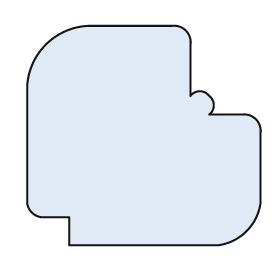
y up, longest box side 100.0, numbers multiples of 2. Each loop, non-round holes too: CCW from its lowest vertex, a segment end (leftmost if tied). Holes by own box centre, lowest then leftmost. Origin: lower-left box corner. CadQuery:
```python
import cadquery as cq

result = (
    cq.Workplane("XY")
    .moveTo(18.0, 0.0)
    .lineTo(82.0, 0.0)
    .threePointArc((94.0, 6.0), (100.0, 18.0))
    .lineTo(100.0, 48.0)
    .threePointArc((98.0, 54.0), (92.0, 56.0))
    .lineTo(78.0, 56.0)
    .threePointArc((80.0, 60.0), (78.0, 64.0))
    .threePointArc((74.0, 66.0), (70.0, 64.0))
    .lineTo(70.0, 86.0)
    .threePointArc((68.0, 92.0), (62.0, 94.0))
    .lineTo(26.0, 94.0)
    .threePointArc((8.0, 86.0), (0.0, 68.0))
    .lineTo(0.0, 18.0)
    .threePointArc((2.0, 14.0), (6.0, 12.0))
    .lineTo(18.0, 12.0)
    .close()
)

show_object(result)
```